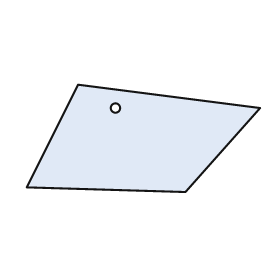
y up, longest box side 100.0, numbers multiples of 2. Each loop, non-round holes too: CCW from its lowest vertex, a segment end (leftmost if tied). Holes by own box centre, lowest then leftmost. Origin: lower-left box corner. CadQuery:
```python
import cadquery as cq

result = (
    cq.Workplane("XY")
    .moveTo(68.0, 0.0)
    .lineTo(100.0, 36.0)
    .lineTo(22.0, 46.0)
    .lineTo(0.0, 2.0)
    .close()
    .moveTo(38.0, 36.0)
    .circle(2.0)
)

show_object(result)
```